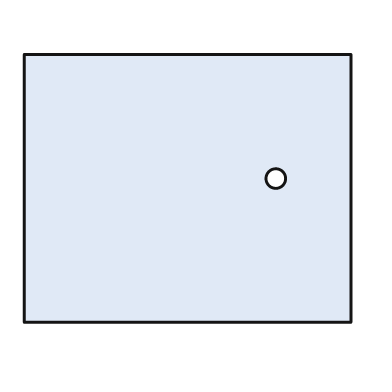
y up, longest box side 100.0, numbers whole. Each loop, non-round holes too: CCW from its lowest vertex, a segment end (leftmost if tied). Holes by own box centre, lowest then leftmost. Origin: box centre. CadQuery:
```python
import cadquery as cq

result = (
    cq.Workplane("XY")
    .moveTo(-50.0, -41.0)
    .lineTo(50.0, -41.0)
    .lineTo(50.0, 41.0)
    .lineTo(-50.0, 41.0)
    .close()
    .moveTo(27.0, 3.0)
    .circle(3.0)
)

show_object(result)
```